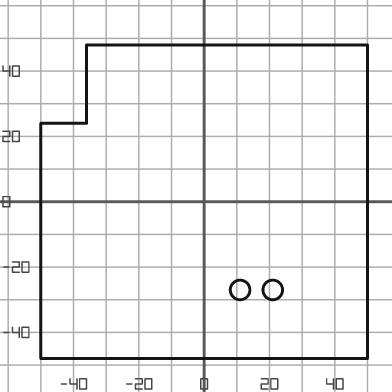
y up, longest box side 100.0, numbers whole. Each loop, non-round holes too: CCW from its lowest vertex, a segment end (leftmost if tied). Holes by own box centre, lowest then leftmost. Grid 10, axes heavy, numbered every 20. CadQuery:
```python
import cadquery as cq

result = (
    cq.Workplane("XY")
    .moveTo(-50.0, -48.0)
    .lineTo(50.0, -48.0)
    .lineTo(50.0, 48.0)
    .lineTo(-36.0, 48.0)
    .lineTo(-36.0, 24.0)
    .lineTo(-50.0, 24.0)
    .close()
    .moveTo(11.0, -27.0)
    .circle(3.0)
    .moveTo(21.0, -27.0)
    .circle(3.0)
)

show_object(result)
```